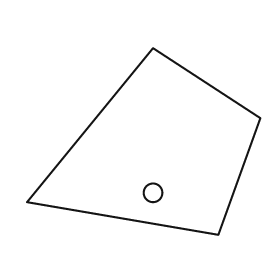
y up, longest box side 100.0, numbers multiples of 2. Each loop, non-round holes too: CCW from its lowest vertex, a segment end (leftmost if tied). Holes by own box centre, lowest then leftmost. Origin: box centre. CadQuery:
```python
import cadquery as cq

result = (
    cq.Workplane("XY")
    .moveTo(32.0, -40.0)
    .lineTo(50.0, 10.0)
    .lineTo(4.0, 40.0)
    .lineTo(-50.0, -26.0)
    .close()
    .moveTo(4.0, -22.0)
    .circle(4.0)
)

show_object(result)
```